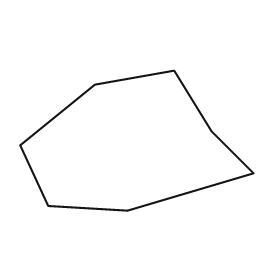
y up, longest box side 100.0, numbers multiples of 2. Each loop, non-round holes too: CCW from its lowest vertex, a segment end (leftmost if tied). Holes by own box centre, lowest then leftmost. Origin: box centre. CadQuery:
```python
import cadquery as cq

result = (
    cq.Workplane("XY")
    .moveTo(-4.0, -30.0)
    .lineTo(50.0, -14.0)
    .lineTo(32.0, 4.0)
    .lineTo(16.0, 30.0)
    .lineTo(-18.0, 24.0)
    .lineTo(-50.0, -2.0)
    .lineTo(-38.0, -28.0)
    .close()
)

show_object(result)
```